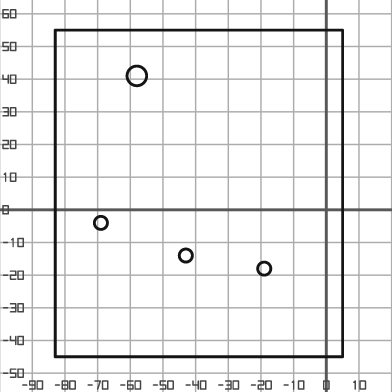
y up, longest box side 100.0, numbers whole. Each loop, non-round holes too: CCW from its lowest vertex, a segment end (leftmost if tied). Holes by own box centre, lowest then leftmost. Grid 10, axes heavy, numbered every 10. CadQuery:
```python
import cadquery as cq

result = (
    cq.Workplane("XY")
    .moveTo(-83.0, -45.0)
    .lineTo(5.0, -45.0)
    .lineTo(5.0, 55.0)
    .lineTo(-83.0, 55.0)
    .close()
    .moveTo(-19.0, -18.0)
    .circle(2.0)
    .moveTo(-43.0, -14.0)
    .circle(2.0)
    .moveTo(-69.0, -4.0)
    .circle(2.0)
    .moveTo(-58.0, 41.0)
    .circle(3.0)
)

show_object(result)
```